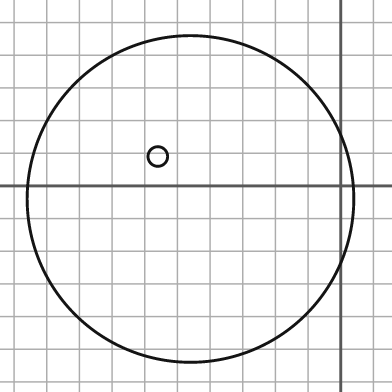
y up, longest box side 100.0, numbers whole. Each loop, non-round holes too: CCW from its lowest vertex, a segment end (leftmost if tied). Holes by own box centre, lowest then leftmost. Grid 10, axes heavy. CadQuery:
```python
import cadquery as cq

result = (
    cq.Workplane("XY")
    .moveTo(-46.0, -4.0)
    .circle(50.0)
    .moveTo(-56.0, 9.0)
    .circle(3.0)
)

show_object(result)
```